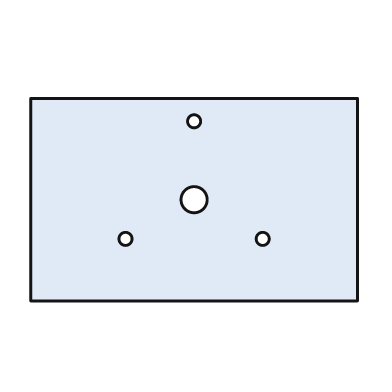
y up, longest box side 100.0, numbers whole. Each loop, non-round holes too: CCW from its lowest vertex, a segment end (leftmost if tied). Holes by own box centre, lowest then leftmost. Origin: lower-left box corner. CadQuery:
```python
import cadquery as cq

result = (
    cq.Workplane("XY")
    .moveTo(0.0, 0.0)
    .lineTo(100.0, 0.0)
    .lineTo(100.0, 62.0)
    .lineTo(0.0, 62.0)
    .close()
    .moveTo(29.0, 19.0)
    .circle(2.0)
    .moveTo(71.0, 19.0)
    .circle(2.0)
    .moveTo(50.0, 31.0)
    .circle(4.0)
    .moveTo(50.0, 55.0)
    .circle(2.0)
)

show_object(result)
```